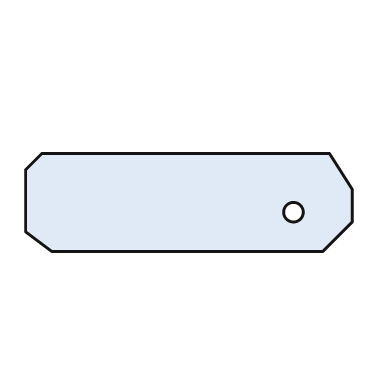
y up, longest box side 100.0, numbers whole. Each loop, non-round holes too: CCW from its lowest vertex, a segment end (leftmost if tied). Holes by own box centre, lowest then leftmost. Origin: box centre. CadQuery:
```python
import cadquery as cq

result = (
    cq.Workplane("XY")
    .moveTo(-42.0, -15.0)
    .lineTo(41.0, -15.0)
    .lineTo(50.0, -6.0)
    .lineTo(50.0, 4.0)
    .lineTo(43.0, 15.0)
    .lineTo(-45.0, 15.0)
    .lineTo(-50.0, 10.0)
    .lineTo(-50.0, -9.0)
    .close()
    .moveTo(32.0, -3.0)
    .circle(3.0)
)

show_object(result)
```